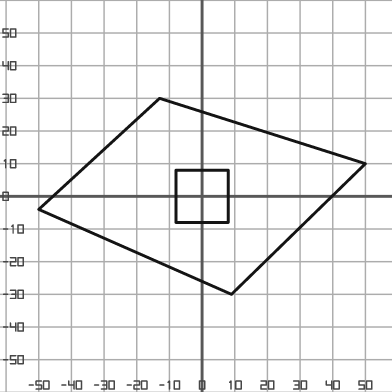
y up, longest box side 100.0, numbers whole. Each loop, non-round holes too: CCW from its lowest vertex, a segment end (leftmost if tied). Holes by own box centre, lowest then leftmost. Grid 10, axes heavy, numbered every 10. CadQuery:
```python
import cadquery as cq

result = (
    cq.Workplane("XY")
    .moveTo(9.0, -30.0)
    .lineTo(50.0, 10.0)
    .lineTo(-13.0, 30.0)
    .lineTo(-50.0, -4.0)
    .close()
    .moveTo(-8.0, -8.0)
    .lineTo(8.0, -8.0)
    .lineTo(8.0, 8.0)
    .lineTo(-8.0, 8.0)
    .close()
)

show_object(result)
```